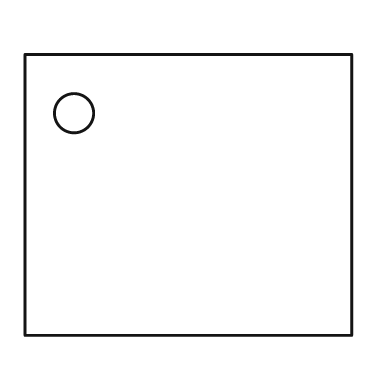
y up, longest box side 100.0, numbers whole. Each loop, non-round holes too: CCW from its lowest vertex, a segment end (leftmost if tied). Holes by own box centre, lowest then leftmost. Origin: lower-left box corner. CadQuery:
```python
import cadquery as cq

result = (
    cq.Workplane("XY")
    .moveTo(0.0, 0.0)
    .lineTo(100.0, 0.0)
    .lineTo(100.0, 86.0)
    .lineTo(0.0, 86.0)
    .close()
    .moveTo(15.0, 68.0)
    .circle(6.0)
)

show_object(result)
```